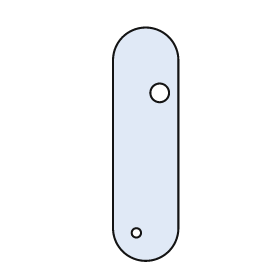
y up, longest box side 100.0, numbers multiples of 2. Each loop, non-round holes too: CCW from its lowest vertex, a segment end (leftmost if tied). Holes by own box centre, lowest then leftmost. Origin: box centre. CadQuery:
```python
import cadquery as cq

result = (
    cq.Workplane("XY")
    .moveTo(-14.0, -36.0)
    .threePointArc((0.0, -50.0), (14.0, -36.0))
    .lineTo(14.0, 36.0)
    .threePointArc((0.0, 50.0), (-14.0, 36.0))
    .close()
    .moveTo(-4.0, -38.0)
    .circle(2.0)
    .moveTo(6.0, 22.0)
    .circle(4.0)
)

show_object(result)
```